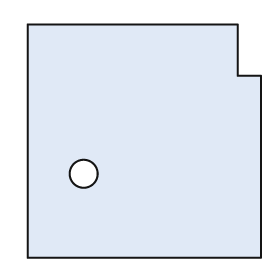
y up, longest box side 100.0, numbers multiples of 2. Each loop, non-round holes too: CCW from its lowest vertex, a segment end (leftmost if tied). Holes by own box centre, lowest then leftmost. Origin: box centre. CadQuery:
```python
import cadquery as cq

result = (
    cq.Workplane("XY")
    .moveTo(-50.0, -50.0)
    .lineTo(50.0, -50.0)
    .lineTo(50.0, 28.0)
    .lineTo(40.0, 28.0)
    .lineTo(40.0, 50.0)
    .lineTo(-50.0, 50.0)
    .close()
    .moveTo(-26.0, -14.0)
    .circle(6.0)
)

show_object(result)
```